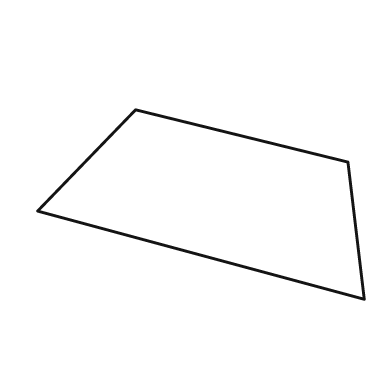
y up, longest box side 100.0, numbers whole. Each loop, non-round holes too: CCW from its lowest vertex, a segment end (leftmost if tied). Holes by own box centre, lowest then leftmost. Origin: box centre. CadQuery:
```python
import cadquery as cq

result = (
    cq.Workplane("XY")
    .moveTo(50.0, -29.0)
    .lineTo(45.0, 13.0)
    .lineTo(-20.0, 29.0)
    .lineTo(-50.0, -2.0)
    .close()
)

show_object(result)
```